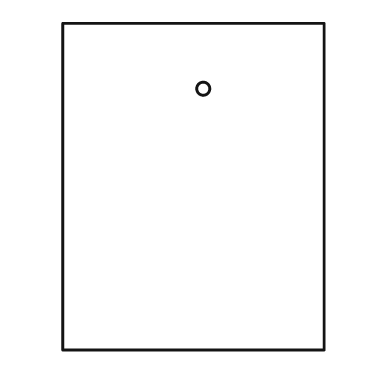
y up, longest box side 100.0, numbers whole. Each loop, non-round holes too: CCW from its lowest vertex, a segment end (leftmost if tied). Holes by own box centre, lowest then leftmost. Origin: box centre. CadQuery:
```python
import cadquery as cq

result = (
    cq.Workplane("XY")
    .moveTo(-40.0, -50.0)
    .lineTo(40.0, -50.0)
    .lineTo(40.0, 50.0)
    .lineTo(-40.0, 50.0)
    .close()
    .moveTo(3.0, 30.0)
    .circle(2.0)
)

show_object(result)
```